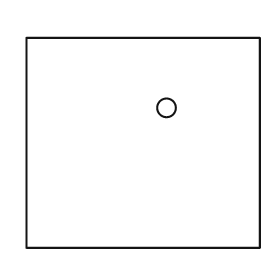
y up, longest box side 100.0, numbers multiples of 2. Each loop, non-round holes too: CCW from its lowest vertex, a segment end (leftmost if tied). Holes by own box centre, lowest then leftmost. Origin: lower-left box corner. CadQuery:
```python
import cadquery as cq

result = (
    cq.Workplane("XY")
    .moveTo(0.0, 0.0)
    .lineTo(100.0, 0.0)
    .lineTo(100.0, 90.0)
    .lineTo(0.0, 90.0)
    .close()
    .moveTo(60.0, 60.0)
    .circle(4.0)
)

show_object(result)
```